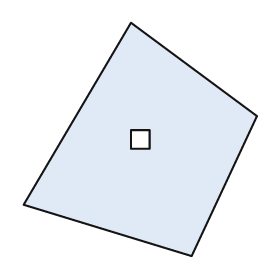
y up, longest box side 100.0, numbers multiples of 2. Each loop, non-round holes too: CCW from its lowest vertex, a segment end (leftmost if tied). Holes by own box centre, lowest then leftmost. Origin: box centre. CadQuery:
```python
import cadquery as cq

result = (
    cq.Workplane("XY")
    .moveTo(22.0, -50.0)
    .lineTo(50.0, 10.0)
    .lineTo(-4.0, 50.0)
    .lineTo(-50.0, -28.0)
    .close()
    .moveTo(-4.0, -4.0)
    .lineTo(4.0, -4.0)
    .lineTo(4.0, 4.0)
    .lineTo(-4.0, 4.0)
    .close()
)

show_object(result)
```